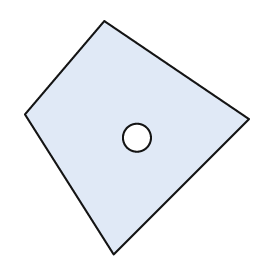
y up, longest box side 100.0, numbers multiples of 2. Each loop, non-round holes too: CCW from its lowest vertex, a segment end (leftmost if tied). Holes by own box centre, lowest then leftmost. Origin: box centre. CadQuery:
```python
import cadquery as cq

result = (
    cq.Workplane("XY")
    .moveTo(-10.0, -50.0)
    .lineTo(48.0, 8.0)
    .lineTo(-14.0, 50.0)
    .lineTo(-48.0, 10.0)
    .close()
    .moveTo(0.0, 0.0)
    .circle(6.0)
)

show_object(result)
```